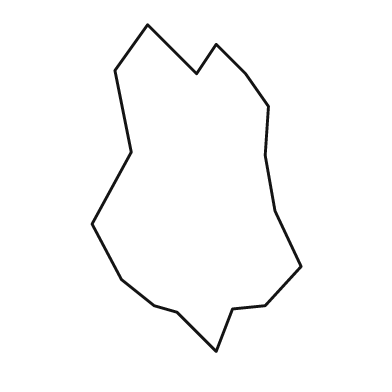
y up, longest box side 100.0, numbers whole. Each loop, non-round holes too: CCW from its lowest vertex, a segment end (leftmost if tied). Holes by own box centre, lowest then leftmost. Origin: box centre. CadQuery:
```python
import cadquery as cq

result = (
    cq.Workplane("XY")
    .moveTo(6.0, -50.0)
    .lineTo(11.0, -37.0)
    .lineTo(21.0, -36.0)
    .lineTo(32.0, -24.0)
    .lineTo(24.0, -7.0)
    .lineTo(21.0, 10.0)
    .lineTo(22.0, 25.0)
    .lineTo(15.0, 35.0)
    .lineTo(6.0, 44.0)
    .lineTo(0.0, 35.0)
    .lineTo(-15.0, 50.0)
    .lineTo(-25.0, 36.0)
    .lineTo(-20.0, 11.0)
    .lineTo(-32.0, -11.0)
    .lineTo(-23.0, -28.0)
    .lineTo(-13.0, -36.0)
    .lineTo(-6.0, -38.0)
    .close()
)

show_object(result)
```